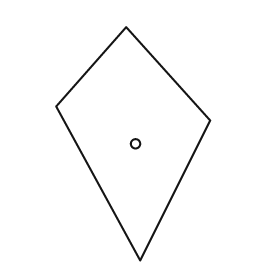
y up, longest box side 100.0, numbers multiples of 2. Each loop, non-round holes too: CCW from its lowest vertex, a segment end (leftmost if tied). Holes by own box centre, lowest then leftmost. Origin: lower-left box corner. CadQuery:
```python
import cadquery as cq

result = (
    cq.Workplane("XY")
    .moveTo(36.0, 0.0)
    .lineTo(66.0, 60.0)
    .lineTo(30.0, 100.0)
    .lineTo(0.0, 66.0)
    .close()
    .moveTo(34.0, 50.0)
    .circle(2.0)
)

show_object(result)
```